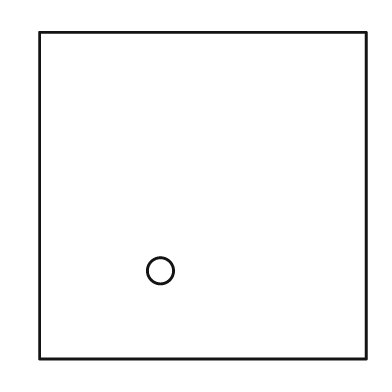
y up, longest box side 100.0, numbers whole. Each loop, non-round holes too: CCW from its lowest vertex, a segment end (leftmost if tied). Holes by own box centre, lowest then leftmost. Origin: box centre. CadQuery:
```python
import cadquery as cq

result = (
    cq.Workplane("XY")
    .moveTo(-50.0, -50.0)
    .lineTo(50.0, -50.0)
    .lineTo(50.0, 50.0)
    .lineTo(-50.0, 50.0)
    .close()
    .moveTo(-13.0, -23.0)
    .circle(4.0)
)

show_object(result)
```